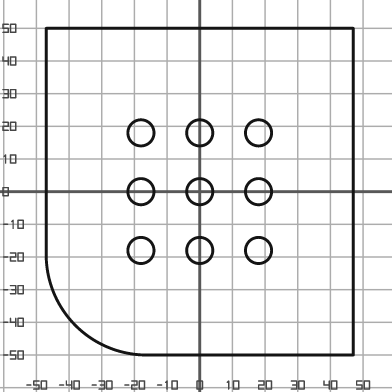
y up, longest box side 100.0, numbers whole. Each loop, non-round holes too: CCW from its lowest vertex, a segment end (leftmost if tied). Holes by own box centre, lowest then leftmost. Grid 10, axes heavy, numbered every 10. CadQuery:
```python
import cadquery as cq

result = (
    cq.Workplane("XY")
    .moveTo(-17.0, -50.0)
    .lineTo(47.0, -50.0)
    .lineTo(47.0, 50.0)
    .lineTo(-47.0, 50.0)
    .lineTo(-47.0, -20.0)
    .threePointArc((-38.0, -41.0), (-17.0, -50.0))
    .close()
    .moveTo(-18.0, -18.0)
    .circle(4.0)
    .moveTo(0.0, -18.0)
    .circle(4.0)
    .moveTo(18.0, -18.0)
    .circle(4.0)
    .moveTo(-18.0, 0.0)
    .circle(4.0)
    .moveTo(0.0, 0.0)
    .circle(4.0)
    .moveTo(18.0, 0.0)
    .circle(4.0)
    .moveTo(-18.0, 18.0)
    .circle(4.0)
    .moveTo(0.0, 18.0)
    .circle(4.0)
    .moveTo(18.0, 18.0)
    .circle(4.0)
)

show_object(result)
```